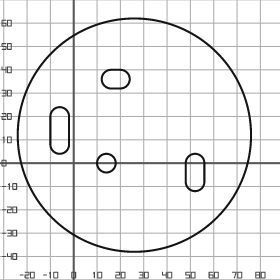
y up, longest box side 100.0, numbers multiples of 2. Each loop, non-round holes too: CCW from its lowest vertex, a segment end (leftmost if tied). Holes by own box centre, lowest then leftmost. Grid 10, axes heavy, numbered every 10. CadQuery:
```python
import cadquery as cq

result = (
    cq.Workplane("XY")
    .moveTo(26.0, 12.0)
    .circle(50.0)
    .moveTo(48.0, -8.0)
    .threePointArc((52.0, -12.0), (56.0, -8.0))
    .lineTo(56.0, 0.0)
    .threePointArc((52.0, 4.0), (48.0, 0.0))
    .close()
    .moveTo(14.0, 0.0)
    .circle(4.0)
    .moveTo(-10.0, 8.0)
    .threePointArc((-6.0, 4.0), (-2.0, 8.0))
    .lineTo(-2.0, 20.0)
    .threePointArc((-6.0, 24.0), (-10.0, 20.0))
    .close()
    .moveTo(16.0, 32.0)
    .lineTo(20.0, 32.0)
    .threePointArc((24.0, 36.0), (20.0, 40.0))
    .lineTo(16.0, 40.0)
    .threePointArc((12.0, 36.0), (16.0, 32.0))
    .close()
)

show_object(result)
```